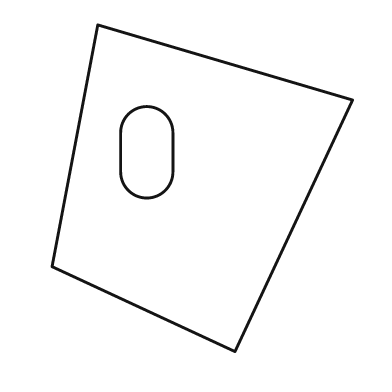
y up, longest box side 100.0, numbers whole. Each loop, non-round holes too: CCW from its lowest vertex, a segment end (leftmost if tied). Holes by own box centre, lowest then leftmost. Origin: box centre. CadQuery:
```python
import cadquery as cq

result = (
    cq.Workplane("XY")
    .moveTo(10.0, -50.0)
    .lineTo(46.0, 27.0)
    .lineTo(-32.0, 50.0)
    .lineTo(-46.0, -24.0)
    .close()
    .moveTo(-25.0, 5.0)
    .threePointArc((-17.0, -3.0), (-9.0, 5.0))
    .lineTo(-9.0, 17.0)
    .threePointArc((-17.0, 25.0), (-25.0, 17.0))
    .close()
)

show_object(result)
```